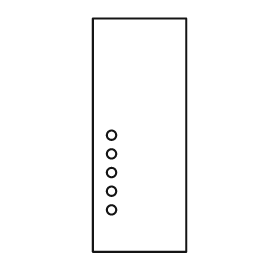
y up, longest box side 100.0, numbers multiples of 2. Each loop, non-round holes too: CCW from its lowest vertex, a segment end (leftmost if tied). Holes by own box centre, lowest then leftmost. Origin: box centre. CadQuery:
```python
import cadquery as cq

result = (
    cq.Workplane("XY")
    .moveTo(-20.0, -50.0)
    .lineTo(20.0, -50.0)
    .lineTo(20.0, 50.0)
    .lineTo(-20.0, 50.0)
    .close()
    .moveTo(-12.0, -32.0)
    .circle(2.0)
    .moveTo(-12.0, -24.0)
    .circle(2.0)
    .moveTo(-12.0, -16.0)
    .circle(2.0)
    .moveTo(-12.0, -8.0)
    .circle(2.0)
    .moveTo(-12.0, 0.0)
    .circle(2.0)
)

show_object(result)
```